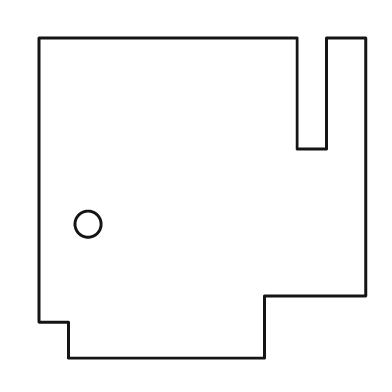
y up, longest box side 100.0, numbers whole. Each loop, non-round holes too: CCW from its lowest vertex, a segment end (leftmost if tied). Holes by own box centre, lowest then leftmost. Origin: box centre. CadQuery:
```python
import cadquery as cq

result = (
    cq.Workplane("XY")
    .moveTo(-41.0, -49.0)
    .lineTo(19.0, -49.0)
    .lineTo(19.0, -30.0)
    .lineTo(50.0, -30.0)
    .lineTo(50.0, 49.0)
    .lineTo(38.0, 49.0)
    .lineTo(38.0, 15.0)
    .lineTo(29.0, 15.0)
    .lineTo(29.0, 49.0)
    .lineTo(-50.0, 49.0)
    .lineTo(-50.0, -38.0)
    .lineTo(-41.0, -38.0)
    .close()
    .moveTo(-35.0, -8.0)
    .circle(4.0)
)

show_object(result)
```